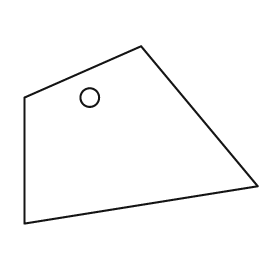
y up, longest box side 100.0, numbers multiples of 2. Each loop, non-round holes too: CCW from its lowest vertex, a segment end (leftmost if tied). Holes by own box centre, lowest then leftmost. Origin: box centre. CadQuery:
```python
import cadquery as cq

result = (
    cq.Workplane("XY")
    .moveTo(-50.0, -38.0)
    .lineTo(50.0, -22.0)
    .lineTo(0.0, 38.0)
    .lineTo(-50.0, 16.0)
    .close()
    .moveTo(-22.0, 16.0)
    .circle(4.0)
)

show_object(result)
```